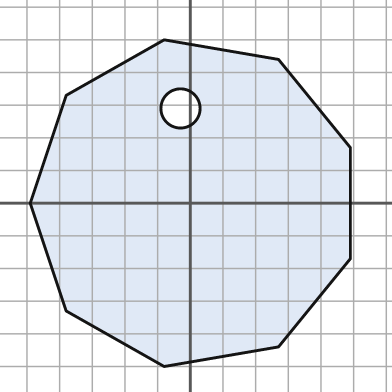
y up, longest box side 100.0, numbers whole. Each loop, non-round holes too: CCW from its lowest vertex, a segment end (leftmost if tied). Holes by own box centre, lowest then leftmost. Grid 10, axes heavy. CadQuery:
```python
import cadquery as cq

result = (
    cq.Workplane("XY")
    .moveTo(-8.0, -50.0)
    .lineTo(27.0, -44.0)
    .lineTo(49.0, -17.0)
    .lineTo(49.0, 17.0)
    .lineTo(27.0, 44.0)
    .lineTo(-8.0, 50.0)
    .lineTo(-38.0, 33.0)
    .lineTo(-49.0, 0.0)
    .lineTo(-38.0, -33.0)
    .close()
    .moveTo(-3.0, 29.0)
    .circle(6.0)
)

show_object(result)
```